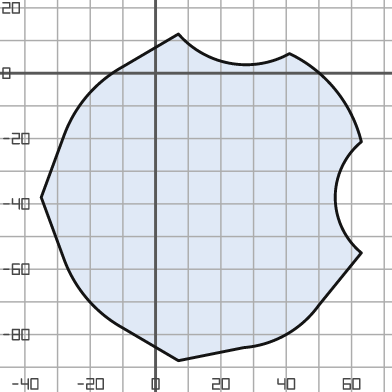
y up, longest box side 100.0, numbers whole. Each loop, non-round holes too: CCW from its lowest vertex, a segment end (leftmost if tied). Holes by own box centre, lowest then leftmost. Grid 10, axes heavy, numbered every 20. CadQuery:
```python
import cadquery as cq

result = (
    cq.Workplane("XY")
    .moveTo(7.0, -88.0)
    .lineTo(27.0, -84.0)
    .threePointArc((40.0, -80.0), (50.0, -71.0))
    .lineTo(63.0, -55.0)
    .threePointArc((55.0, -38.0), (63.0, -21.0))
    .threePointArc((55.0, -5.0), (41.0, 6.0))
    .threePointArc((23.0, 3.0), (7.0, 12.0))
    .lineTo(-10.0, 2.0)
    .threePointArc((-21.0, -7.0), (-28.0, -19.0))
    .lineTo(-35.0, -38.0)
    .lineTo(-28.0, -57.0)
    .threePointArc((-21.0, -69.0), (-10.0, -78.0))
    .close()
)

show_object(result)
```